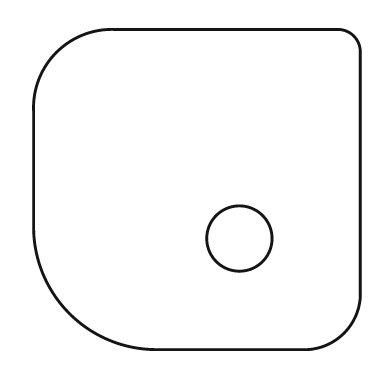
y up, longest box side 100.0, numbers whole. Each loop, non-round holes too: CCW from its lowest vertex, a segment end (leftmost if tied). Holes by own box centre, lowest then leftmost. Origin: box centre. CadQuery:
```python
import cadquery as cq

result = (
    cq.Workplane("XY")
    .moveTo(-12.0, -49.0)
    .lineTo(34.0, -49.0)
    .threePointArc((45.0, -44.0), (50.0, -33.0))
    .lineTo(50.0, 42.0)
    .threePointArc((48.0, 47.0), (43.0, 49.0))
    .lineTo(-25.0, 49.0)
    .threePointArc((-43.0, 42.0), (-50.0, 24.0))
    .lineTo(-50.0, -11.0)
    .threePointArc((-39.0, -38.0), (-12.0, -49.0))
    .close()
    .moveTo(13.0, -15.0)
    .circle(10.0)
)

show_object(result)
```